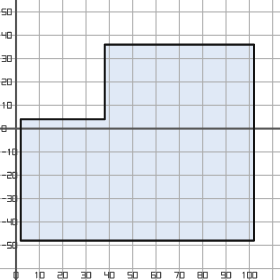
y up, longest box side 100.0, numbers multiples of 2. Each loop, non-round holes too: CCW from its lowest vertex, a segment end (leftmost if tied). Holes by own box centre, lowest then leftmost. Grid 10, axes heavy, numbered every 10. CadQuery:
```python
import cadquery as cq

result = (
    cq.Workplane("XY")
    .moveTo(2.0, -48.0)
    .lineTo(102.0, -48.0)
    .lineTo(102.0, 36.0)
    .lineTo(38.0, 36.0)
    .lineTo(38.0, 4.0)
    .lineTo(2.0, 4.0)
    .close()
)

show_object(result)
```